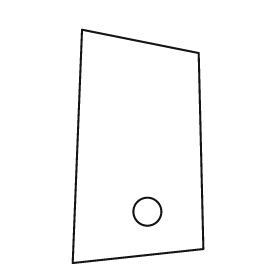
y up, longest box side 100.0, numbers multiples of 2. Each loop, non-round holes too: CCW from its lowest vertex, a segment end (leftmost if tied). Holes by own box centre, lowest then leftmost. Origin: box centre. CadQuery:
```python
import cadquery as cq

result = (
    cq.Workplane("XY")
    .moveTo(-28.0, -50.0)
    .lineTo(28.0, -44.0)
    .lineTo(26.0, 40.0)
    .lineTo(-24.0, 50.0)
    .close()
    .moveTo(4.0, -28.0)
    .circle(6.0)
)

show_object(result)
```